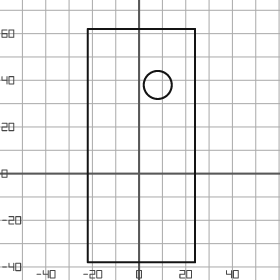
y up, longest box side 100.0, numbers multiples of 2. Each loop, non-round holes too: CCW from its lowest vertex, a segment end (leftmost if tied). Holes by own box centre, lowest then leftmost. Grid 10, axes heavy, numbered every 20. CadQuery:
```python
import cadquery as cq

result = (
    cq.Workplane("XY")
    .moveTo(-22.0, -38.0)
    .lineTo(24.0, -38.0)
    .lineTo(24.0, 62.0)
    .lineTo(-22.0, 62.0)
    .close()
    .moveTo(8.0, 38.0)
    .circle(6.0)
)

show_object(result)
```